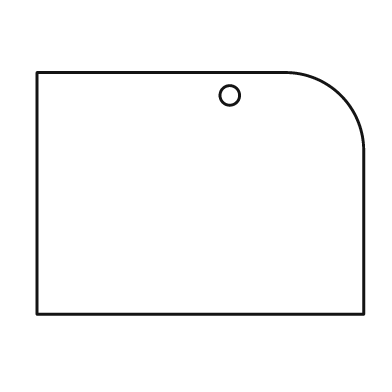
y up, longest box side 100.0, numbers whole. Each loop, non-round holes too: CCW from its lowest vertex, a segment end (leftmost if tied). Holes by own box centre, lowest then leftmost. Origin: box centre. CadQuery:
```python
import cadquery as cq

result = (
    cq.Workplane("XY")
    .moveTo(-50.0, -37.0)
    .lineTo(50.0, -37.0)
    .lineTo(50.0, 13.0)
    .threePointArc((43.0, 30.0), (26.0, 37.0))
    .lineTo(-50.0, 37.0)
    .close()
    .moveTo(9.0, 30.0)
    .circle(3.0)
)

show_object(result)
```